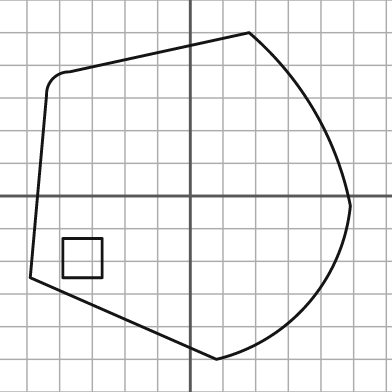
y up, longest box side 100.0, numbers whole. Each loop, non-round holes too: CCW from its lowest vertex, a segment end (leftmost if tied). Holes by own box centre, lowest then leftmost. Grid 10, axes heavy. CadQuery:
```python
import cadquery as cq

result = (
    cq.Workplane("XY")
    .moveTo(8.0, -50.0)
    .threePointArc((36.0, -33.0), (49.0, -3.0))
    .threePointArc((38.0, 26.0), (18.0, 50.0))
    .lineTo(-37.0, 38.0)
    .threePointArc((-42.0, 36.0), (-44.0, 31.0))
    .lineTo(-49.0, -25.0)
    .close()
    .moveTo(-39.0, -25.0)
    .lineTo(-27.0, -25.0)
    .lineTo(-27.0, -13.0)
    .lineTo(-39.0, -13.0)
    .close()
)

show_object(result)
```